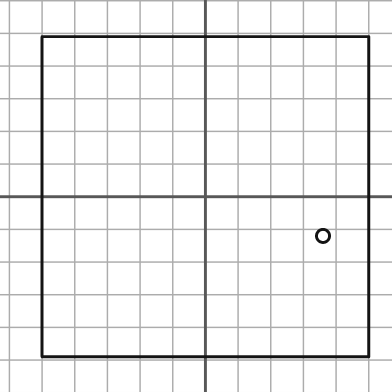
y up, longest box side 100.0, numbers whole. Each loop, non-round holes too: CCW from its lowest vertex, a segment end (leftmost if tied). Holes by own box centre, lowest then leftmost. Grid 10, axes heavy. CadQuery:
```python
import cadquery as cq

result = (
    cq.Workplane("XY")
    .moveTo(-50.0, -49.0)
    .lineTo(50.0, -49.0)
    .lineTo(50.0, 49.0)
    .lineTo(-50.0, 49.0)
    .close()
    .moveTo(36.0, -12.0)
    .circle(2.0)
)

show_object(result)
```